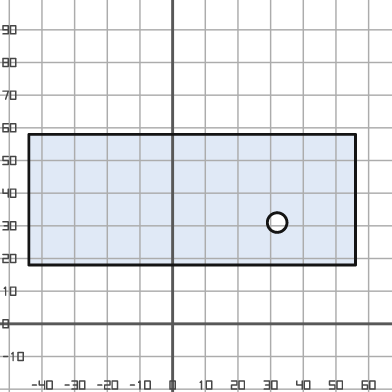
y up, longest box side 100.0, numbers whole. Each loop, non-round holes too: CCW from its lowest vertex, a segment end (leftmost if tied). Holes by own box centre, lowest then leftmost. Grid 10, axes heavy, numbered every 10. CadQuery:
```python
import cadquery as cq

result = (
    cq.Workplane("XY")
    .moveTo(-44.0, 18.0)
    .lineTo(56.0, 18.0)
    .lineTo(56.0, 58.0)
    .lineTo(-44.0, 58.0)
    .close()
    .moveTo(32.0, 31.0)
    .circle(3.0)
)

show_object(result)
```